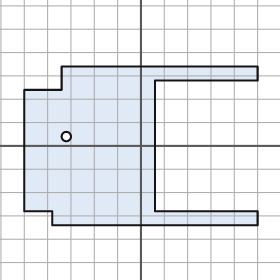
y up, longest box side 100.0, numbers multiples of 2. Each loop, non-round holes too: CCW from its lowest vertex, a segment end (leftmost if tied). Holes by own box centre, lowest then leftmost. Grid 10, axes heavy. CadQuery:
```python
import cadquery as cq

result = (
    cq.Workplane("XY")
    .moveTo(-38.0, -34.0)
    .lineTo(50.0, -34.0)
    .lineTo(50.0, -28.0)
    .lineTo(6.0, -28.0)
    .lineTo(6.0, 28.0)
    .lineTo(50.0, 28.0)
    .lineTo(50.0, 34.0)
    .lineTo(-34.0, 34.0)
    .lineTo(-34.0, 24.0)
    .lineTo(-50.0, 24.0)
    .lineTo(-50.0, -28.0)
    .lineTo(-38.0, -28.0)
    .close()
    .moveTo(-32.0, 4.0)
    .circle(2.0)
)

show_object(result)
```